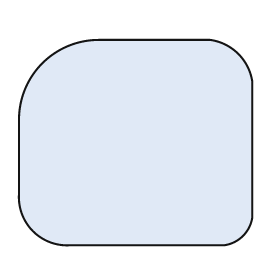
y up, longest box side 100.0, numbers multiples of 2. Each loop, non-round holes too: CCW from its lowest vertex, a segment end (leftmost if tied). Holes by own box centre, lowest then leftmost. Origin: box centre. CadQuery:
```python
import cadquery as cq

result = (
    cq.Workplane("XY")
    .moveTo(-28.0, -44.0)
    .lineTo(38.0, -44.0)
    .threePointArc((46.0, -40.0), (50.0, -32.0))
    .lineTo(50.0, 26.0)
    .threePointArc((44.0, 38.0), (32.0, 44.0))
    .lineTo(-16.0, 44.0)
    .threePointArc((-40.0, 34.0), (-50.0, 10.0))
    .lineTo(-50.0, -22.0)
    .threePointArc((-44.0, -38.0), (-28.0, -44.0))
    .close()
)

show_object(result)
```